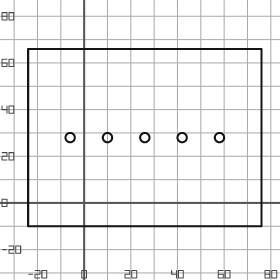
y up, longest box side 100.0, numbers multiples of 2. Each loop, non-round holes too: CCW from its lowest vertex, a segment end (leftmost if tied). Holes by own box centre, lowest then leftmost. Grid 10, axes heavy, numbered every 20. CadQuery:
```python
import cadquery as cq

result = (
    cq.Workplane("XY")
    .moveTo(-24.0, -10.0)
    .lineTo(76.0, -10.0)
    .lineTo(76.0, 66.0)
    .lineTo(-24.0, 66.0)
    .close()
    .moveTo(-6.0, 28.0)
    .circle(2.0)
    .moveTo(10.0, 28.0)
    .circle(2.0)
    .moveTo(26.0, 28.0)
    .circle(2.0)
    .moveTo(42.0, 28.0)
    .circle(2.0)
    .moveTo(58.0, 28.0)
    .circle(2.0)
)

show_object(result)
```